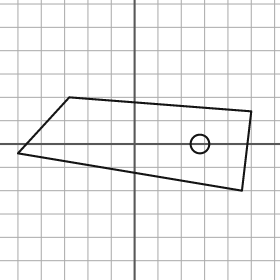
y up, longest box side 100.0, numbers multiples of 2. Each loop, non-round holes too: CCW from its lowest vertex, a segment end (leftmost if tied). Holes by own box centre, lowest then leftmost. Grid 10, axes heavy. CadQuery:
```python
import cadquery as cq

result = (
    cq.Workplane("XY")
    .moveTo(46.0, -20.0)
    .lineTo(50.0, 14.0)
    .lineTo(-28.0, 20.0)
    .lineTo(-50.0, -4.0)
    .close()
    .moveTo(28.0, 0.0)
    .circle(4.0)
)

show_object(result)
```